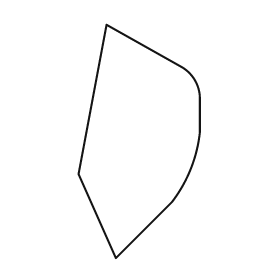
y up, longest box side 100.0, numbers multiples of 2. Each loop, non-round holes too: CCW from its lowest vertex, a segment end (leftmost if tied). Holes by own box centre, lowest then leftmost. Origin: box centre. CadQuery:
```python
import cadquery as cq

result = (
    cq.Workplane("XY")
    .moveTo(-10.0, -50.0)
    .lineTo(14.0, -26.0)
    .threePointArc((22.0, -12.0), (26.0, 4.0))
    .lineTo(26.0, 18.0)
    .threePointArc((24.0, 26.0), (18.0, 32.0))
    .lineTo(-14.0, 50.0)
    .lineTo(-26.0, -14.0)
    .close()
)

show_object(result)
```